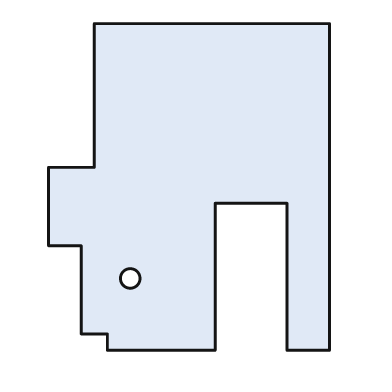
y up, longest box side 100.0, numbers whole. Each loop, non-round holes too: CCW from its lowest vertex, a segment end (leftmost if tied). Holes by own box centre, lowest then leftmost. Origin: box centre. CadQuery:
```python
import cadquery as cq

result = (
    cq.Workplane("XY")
    .moveTo(-25.0, -50.0)
    .lineTo(8.0, -50.0)
    .lineTo(8.0, -5.0)
    .lineTo(30.0, -5.0)
    .lineTo(30.0, -50.0)
    .lineTo(43.0, -50.0)
    .lineTo(43.0, 50.0)
    .lineTo(-29.0, 50.0)
    .lineTo(-29.0, 6.0)
    .lineTo(-43.0, 6.0)
    .lineTo(-43.0, -18.0)
    .lineTo(-33.0, -18.0)
    .lineTo(-33.0, -45.0)
    .lineTo(-25.0, -45.0)
    .close()
    .moveTo(-18.0, -28.0)
    .circle(3.0)
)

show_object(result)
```